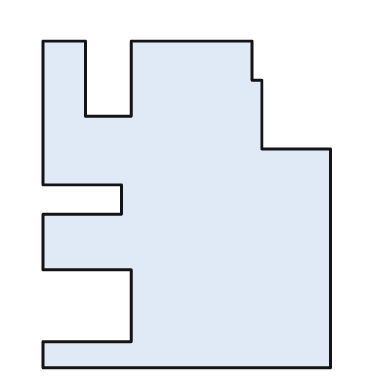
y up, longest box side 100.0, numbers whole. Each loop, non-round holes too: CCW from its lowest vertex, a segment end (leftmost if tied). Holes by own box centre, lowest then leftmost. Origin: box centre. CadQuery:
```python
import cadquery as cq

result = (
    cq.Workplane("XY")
    .moveTo(-44.0, -50.0)
    .lineTo(44.0, -50.0)
    .lineTo(44.0, 17.0)
    .lineTo(23.0, 17.0)
    .lineTo(23.0, 38.0)
    .lineTo(20.0, 38.0)
    .lineTo(20.0, 50.0)
    .lineTo(-17.0, 50.0)
    .lineTo(-17.0, 27.0)
    .lineTo(-31.0, 27.0)
    .lineTo(-31.0, 50.0)
    .lineTo(-44.0, 50.0)
    .lineTo(-44.0, 6.0)
    .lineTo(-20.0, 6.0)
    .lineTo(-20.0, -3.0)
    .lineTo(-44.0, -3.0)
    .lineTo(-44.0, -20.0)
    .lineTo(-17.0, -20.0)
    .lineTo(-17.0, -42.0)
    .lineTo(-44.0, -42.0)
    .close()
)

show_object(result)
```